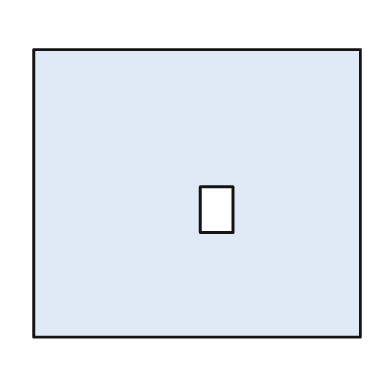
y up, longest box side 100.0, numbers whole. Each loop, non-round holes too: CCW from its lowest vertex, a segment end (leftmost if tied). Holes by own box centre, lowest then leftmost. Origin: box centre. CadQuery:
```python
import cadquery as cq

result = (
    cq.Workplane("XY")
    .moveTo(-50.0, -44.0)
    .lineTo(50.0, -44.0)
    .lineTo(50.0, 44.0)
    .lineTo(-50.0, 44.0)
    .close()
    .moveTo(1.0, -12.0)
    .lineTo(11.0, -12.0)
    .lineTo(11.0, 2.0)
    .lineTo(1.0, 2.0)
    .close()
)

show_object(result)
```